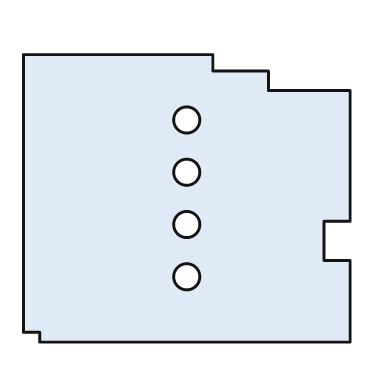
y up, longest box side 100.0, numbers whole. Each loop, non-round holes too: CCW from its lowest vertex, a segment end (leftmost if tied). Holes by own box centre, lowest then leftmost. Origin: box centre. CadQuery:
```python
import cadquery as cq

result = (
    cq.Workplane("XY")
    .moveTo(-45.0, -44.0)
    .lineTo(50.0, -44.0)
    .lineTo(50.0, -19.0)
    .lineTo(42.0, -19.0)
    .lineTo(42.0, -7.0)
    .lineTo(50.0, -7.0)
    .lineTo(50.0, 33.0)
    .lineTo(25.0, 33.0)
    .lineTo(25.0, 39.0)
    .lineTo(8.0, 39.0)
    .lineTo(8.0, 44.0)
    .lineTo(-50.0, 44.0)
    .lineTo(-50.0, -41.0)
    .lineTo(-45.0, -41.0)
    .close()
    .moveTo(0.0, -24.0)
    .circle(4.0)
    .moveTo(0.0, -8.0)
    .circle(4.0)
    .moveTo(0.0, 8.0)
    .circle(4.0)
    .moveTo(0.0, 24.0)
    .circle(4.0)
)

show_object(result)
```